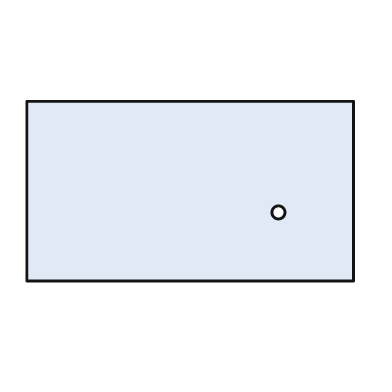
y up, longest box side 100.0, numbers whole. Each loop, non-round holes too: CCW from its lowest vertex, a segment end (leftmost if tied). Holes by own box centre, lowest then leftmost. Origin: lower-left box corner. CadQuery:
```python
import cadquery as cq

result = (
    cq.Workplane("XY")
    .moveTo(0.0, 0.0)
    .lineTo(100.0, 0.0)
    .lineTo(100.0, 55.0)
    .lineTo(0.0, 55.0)
    .close()
    .moveTo(77.0, 21.0)
    .circle(2.0)
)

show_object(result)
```